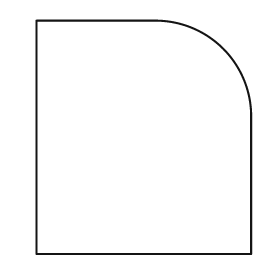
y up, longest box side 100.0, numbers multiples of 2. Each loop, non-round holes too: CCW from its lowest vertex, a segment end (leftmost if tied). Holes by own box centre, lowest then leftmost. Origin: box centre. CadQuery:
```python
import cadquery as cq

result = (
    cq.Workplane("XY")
    .moveTo(-46.0, -50.0)
    .lineTo(46.0, -50.0)
    .lineTo(46.0, 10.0)
    .threePointArc((34.0, 38.0), (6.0, 50.0))
    .lineTo(-46.0, 50.0)
    .close()
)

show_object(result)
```